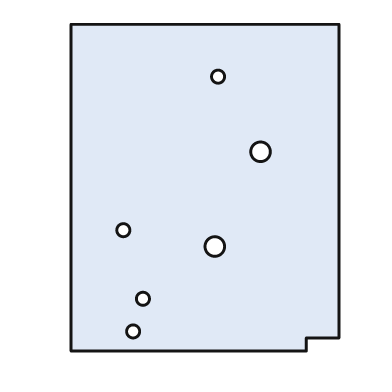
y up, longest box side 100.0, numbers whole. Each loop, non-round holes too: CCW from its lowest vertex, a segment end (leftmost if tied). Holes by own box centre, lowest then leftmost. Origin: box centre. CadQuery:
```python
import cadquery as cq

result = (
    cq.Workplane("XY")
    .moveTo(-41.0, -50.0)
    .lineTo(31.0, -50.0)
    .lineTo(31.0, -46.0)
    .lineTo(41.0, -46.0)
    .lineTo(41.0, 50.0)
    .lineTo(-41.0, 50.0)
    .close()
    .moveTo(-22.0, -44.0)
    .circle(2.0)
    .moveTo(-19.0, -34.0)
    .circle(2.0)
    .moveTo(3.0, -18.0)
    .circle(3.0)
    .moveTo(-25.0, -13.0)
    .circle(2.0)
    .moveTo(17.0, 11.0)
    .circle(3.0)
    .moveTo(4.0, 34.0)
    .circle(2.0)
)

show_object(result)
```